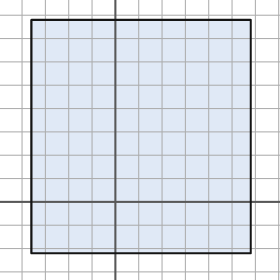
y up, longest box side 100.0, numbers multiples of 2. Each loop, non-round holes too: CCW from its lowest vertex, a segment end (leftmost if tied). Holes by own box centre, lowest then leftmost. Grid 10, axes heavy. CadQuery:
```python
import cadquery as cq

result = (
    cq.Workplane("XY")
    .moveTo(-36.0, -22.0)
    .lineTo(58.0, -22.0)
    .lineTo(58.0, 78.0)
    .lineTo(-36.0, 78.0)
    .close()
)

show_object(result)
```